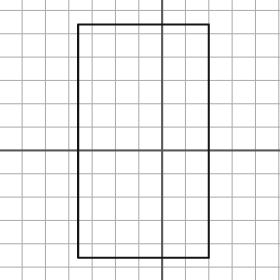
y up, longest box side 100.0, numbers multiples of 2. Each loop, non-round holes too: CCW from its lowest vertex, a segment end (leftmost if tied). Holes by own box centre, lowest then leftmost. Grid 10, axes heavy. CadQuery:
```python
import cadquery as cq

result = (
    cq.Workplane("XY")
    .moveTo(-36.0, -46.0)
    .lineTo(20.0, -46.0)
    .lineTo(20.0, 54.0)
    .lineTo(-36.0, 54.0)
    .close()
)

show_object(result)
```